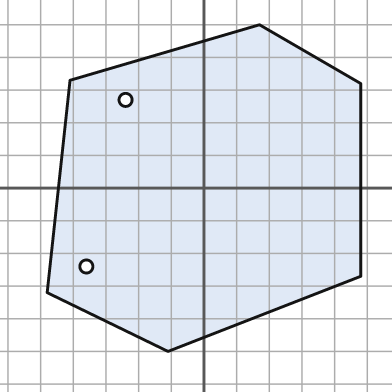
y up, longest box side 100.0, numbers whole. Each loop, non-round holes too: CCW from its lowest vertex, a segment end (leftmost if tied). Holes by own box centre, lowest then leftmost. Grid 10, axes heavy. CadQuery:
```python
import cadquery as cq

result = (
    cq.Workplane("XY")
    .moveTo(-11.0, -50.0)
    .lineTo(48.0, -27.0)
    .lineTo(48.0, 32.0)
    .lineTo(17.0, 50.0)
    .lineTo(-41.0, 33.0)
    .lineTo(-48.0, -32.0)
    .close()
    .moveTo(-36.0, -24.0)
    .circle(2.0)
    .moveTo(-24.0, 27.0)
    .circle(2.0)
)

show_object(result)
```